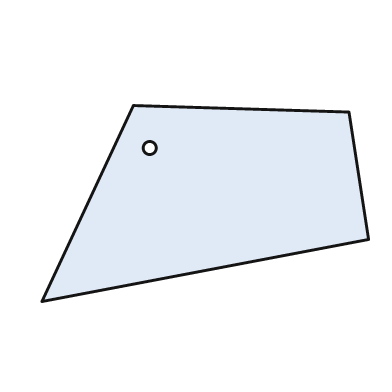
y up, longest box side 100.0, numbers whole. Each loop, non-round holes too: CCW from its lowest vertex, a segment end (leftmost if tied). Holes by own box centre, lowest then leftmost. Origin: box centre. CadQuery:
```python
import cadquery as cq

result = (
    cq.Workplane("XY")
    .moveTo(-50.0, -30.0)
    .lineTo(50.0, -11.0)
    .lineTo(44.0, 28.0)
    .lineTo(-22.0, 30.0)
    .close()
    .moveTo(-17.0, 17.0)
    .circle(2.0)
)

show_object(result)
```